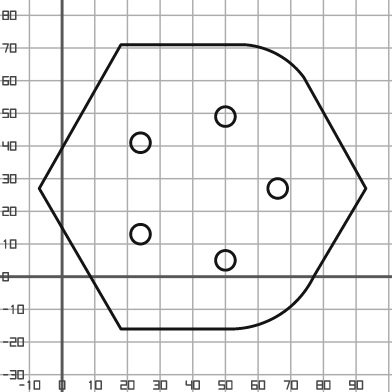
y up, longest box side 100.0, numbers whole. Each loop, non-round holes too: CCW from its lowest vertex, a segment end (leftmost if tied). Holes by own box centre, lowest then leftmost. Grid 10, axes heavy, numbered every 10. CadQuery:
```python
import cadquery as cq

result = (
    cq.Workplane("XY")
    .moveTo(18.0, -16.0)
    .lineTo(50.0, -16.0)
    .threePointArc((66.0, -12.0), (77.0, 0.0))
    .lineTo(93.0, 27.0)
    .lineTo(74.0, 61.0)
    .threePointArc((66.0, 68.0), (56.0, 71.0))
    .lineTo(18.0, 71.0)
    .lineTo(-7.0, 27.0)
    .close()
    .moveTo(50.0, 5.0)
    .circle(3.0)
    .moveTo(24.0, 13.0)
    .circle(3.0)
    .moveTo(66.0, 27.0)
    .circle(3.0)
    .moveTo(24.0, 41.0)
    .circle(3.0)
    .moveTo(50.0, 49.0)
    .circle(3.0)
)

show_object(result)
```